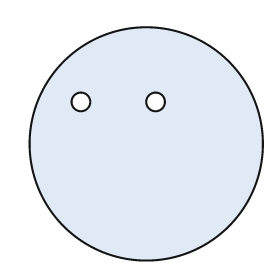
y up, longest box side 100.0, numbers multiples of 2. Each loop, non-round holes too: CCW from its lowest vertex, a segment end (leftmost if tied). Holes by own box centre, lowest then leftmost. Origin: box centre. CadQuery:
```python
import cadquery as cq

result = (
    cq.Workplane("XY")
    .moveTo(0.0, 0.0)
    .circle(50.0)
    .moveTo(-28.0, 18.0)
    .circle(4.0)
    .moveTo(4.0, 18.0)
    .circle(4.0)
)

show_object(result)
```